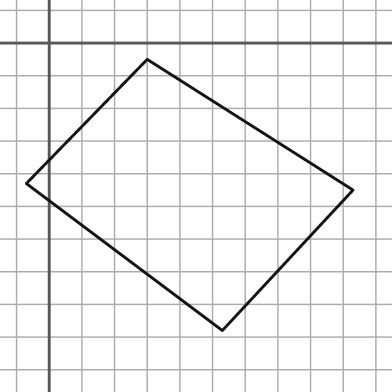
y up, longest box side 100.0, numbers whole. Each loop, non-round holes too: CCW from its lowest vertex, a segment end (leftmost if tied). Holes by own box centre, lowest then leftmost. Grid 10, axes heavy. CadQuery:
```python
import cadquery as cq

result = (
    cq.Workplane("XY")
    .moveTo(53.0, -88.0)
    .lineTo(93.0, -45.0)
    .lineTo(30.0, -5.0)
    .lineTo(-7.0, -43.0)
    .close()
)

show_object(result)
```